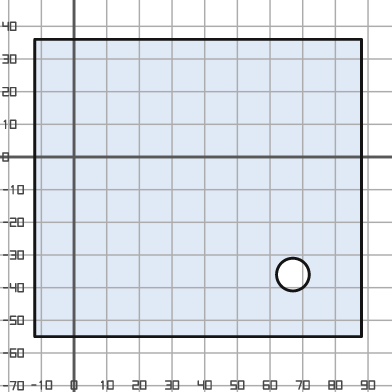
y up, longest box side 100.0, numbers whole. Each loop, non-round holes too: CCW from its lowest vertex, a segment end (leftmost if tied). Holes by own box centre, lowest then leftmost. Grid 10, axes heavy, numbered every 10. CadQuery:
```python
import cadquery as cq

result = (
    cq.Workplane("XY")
    .moveTo(-12.0, -55.0)
    .lineTo(88.0, -55.0)
    .lineTo(88.0, 36.0)
    .lineTo(-12.0, 36.0)
    .close()
    .moveTo(67.0, -36.0)
    .circle(5.0)
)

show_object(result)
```